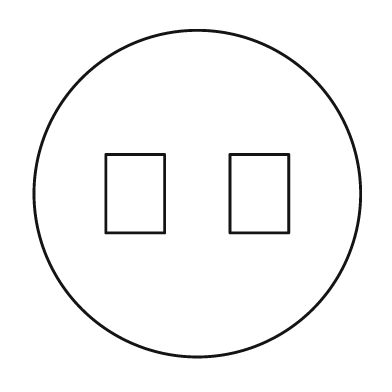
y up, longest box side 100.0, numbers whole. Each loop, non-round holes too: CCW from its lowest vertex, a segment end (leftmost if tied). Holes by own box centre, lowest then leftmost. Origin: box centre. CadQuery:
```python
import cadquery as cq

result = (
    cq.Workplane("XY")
    .moveTo(0.0, 0.0)
    .circle(50.0)
    .moveTo(-28.0, -12.0)
    .lineTo(-10.0, -12.0)
    .lineTo(-10.0, 12.0)
    .lineTo(-28.0, 12.0)
    .close()
    .moveTo(10.0, -12.0)
    .lineTo(28.0, -12.0)
    .lineTo(28.0, 12.0)
    .lineTo(10.0, 12.0)
    .close()
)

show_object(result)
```